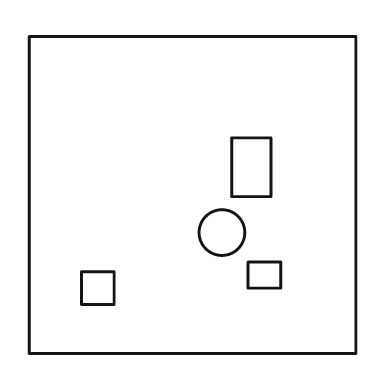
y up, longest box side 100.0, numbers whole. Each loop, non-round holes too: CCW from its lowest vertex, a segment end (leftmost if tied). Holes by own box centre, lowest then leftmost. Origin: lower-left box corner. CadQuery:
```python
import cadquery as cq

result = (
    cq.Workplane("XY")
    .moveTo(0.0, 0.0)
    .lineTo(100.0, 0.0)
    .lineTo(100.0, 97.0)
    .lineTo(0.0, 97.0)
    .close()
    .moveTo(16.0, 15.0)
    .lineTo(26.0, 15.0)
    .lineTo(26.0, 25.0)
    .lineTo(16.0, 25.0)
    .close()
    .moveTo(67.0, 20.0)
    .lineTo(77.0, 20.0)
    .lineTo(77.0, 28.0)
    .lineTo(67.0, 28.0)
    .close()
    .moveTo(59.0, 37.0)
    .circle(7.0)
    .moveTo(62.0, 48.0)
    .lineTo(74.0, 48.0)
    .lineTo(74.0, 66.0)
    .lineTo(62.0, 66.0)
    .close()
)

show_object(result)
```